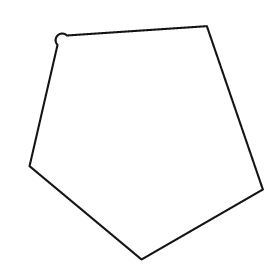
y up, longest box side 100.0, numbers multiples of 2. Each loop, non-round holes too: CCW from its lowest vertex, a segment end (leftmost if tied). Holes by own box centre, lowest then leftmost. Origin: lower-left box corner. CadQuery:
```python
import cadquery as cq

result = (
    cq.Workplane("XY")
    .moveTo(48.0, 0.0)
    .lineTo(100.0, 30.0)
    .lineTo(76.0, 100.0)
    .lineTo(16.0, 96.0)
    .threePointArc((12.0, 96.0), (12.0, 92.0))
    .lineTo(0.0, 40.0)
    .close()
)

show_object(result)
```